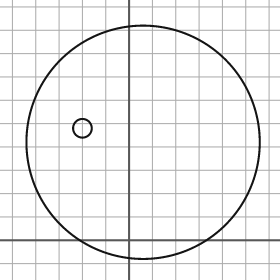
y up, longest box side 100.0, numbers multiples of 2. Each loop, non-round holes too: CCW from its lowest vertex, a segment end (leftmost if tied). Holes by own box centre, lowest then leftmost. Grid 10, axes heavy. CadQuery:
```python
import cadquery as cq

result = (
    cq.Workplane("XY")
    .moveTo(6.0, 42.0)
    .circle(50.0)
    .moveTo(-20.0, 48.0)
    .circle(4.0)
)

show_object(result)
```